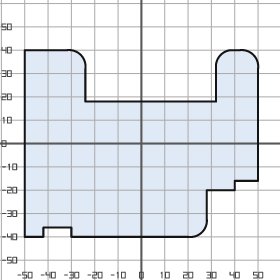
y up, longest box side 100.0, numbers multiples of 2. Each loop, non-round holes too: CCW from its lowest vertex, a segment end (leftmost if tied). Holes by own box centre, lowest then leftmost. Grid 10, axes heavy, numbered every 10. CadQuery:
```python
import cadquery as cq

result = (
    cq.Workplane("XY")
    .moveTo(-50.0, -40.0)
    .lineTo(-42.0, -40.0)
    .lineTo(-42.0, -36.0)
    .lineTo(-30.0, -36.0)
    .lineTo(-30.0, -40.0)
    .lineTo(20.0, -40.0)
    .threePointArc((26.0, -38.0), (28.0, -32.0))
    .lineTo(28.0, -20.0)
    .lineTo(40.0, -20.0)
    .lineTo(40.0, -16.0)
    .lineTo(50.0, -16.0)
    .lineTo(50.0, 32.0)
    .threePointArc((48.0, 38.0), (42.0, 40.0))
    .lineTo(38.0, 40.0)
    .threePointArc((34.0, 38.0), (32.0, 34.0))
    .lineTo(32.0, 18.0)
    .lineTo(-24.0, 18.0)
    .lineTo(-24.0, 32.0)
    .threePointArc((-26.0, 38.0), (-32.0, 40.0))
    .lineTo(-50.0, 40.0)
    .close()
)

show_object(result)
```